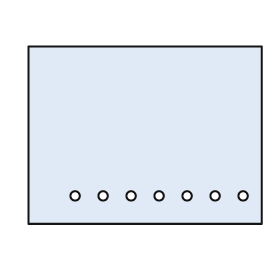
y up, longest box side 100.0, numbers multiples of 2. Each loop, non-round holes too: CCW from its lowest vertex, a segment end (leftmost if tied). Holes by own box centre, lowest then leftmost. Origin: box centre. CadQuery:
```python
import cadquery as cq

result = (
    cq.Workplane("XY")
    .moveTo(-50.0, -38.0)
    .lineTo(50.0, -38.0)
    .lineTo(50.0, 38.0)
    .lineTo(-50.0, 38.0)
    .close()
    .moveTo(-30.0, -26.0)
    .circle(2.0)
    .moveTo(-18.0, -26.0)
    .circle(2.0)
    .moveTo(-6.0, -26.0)
    .circle(2.0)
    .moveTo(6.0, -26.0)
    .circle(2.0)
    .moveTo(18.0, -26.0)
    .circle(2.0)
    .moveTo(30.0, -26.0)
    .circle(2.0)
    .moveTo(42.0, -26.0)
    .circle(2.0)
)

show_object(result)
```